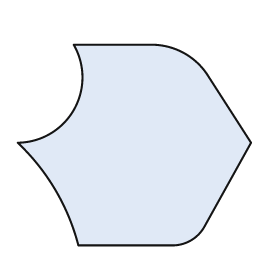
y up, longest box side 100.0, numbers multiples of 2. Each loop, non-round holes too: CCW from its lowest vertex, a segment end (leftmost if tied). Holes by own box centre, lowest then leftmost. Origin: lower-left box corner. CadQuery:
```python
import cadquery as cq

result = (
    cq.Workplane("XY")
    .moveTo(26.0, 0.0)
    .lineTo(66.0, 0.0)
    .threePointArc((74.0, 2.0), (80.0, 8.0))
    .lineTo(100.0, 44.0)
    .lineTo(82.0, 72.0)
    .threePointArc((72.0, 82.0), (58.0, 86.0))
    .lineTo(24.0, 86.0)
    .threePointArc((24.0, 58.0), (0.0, 44.0))
    .threePointArc((16.0, 24.0), (26.0, 0.0))
    .close()
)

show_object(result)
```